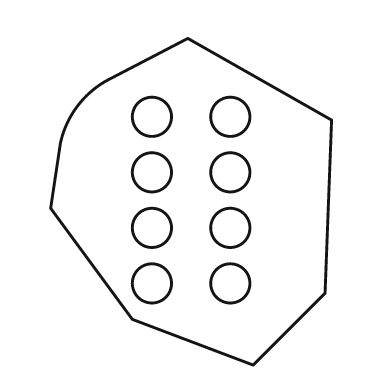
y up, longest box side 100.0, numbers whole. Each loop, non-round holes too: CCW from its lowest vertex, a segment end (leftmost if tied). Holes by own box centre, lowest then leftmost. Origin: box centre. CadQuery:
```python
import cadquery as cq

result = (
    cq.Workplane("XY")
    .moveTo(19.0, -50.0)
    .lineTo(41.0, -28.0)
    .lineTo(43.0, 25.0)
    .lineTo(-1.0, 50.0)
    .lineTo(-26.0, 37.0)
    .threePointArc((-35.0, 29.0), (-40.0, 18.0))
    .lineTo(-43.0, -2.0)
    .lineTo(-18.0, -36.0)
    .close()
    .moveTo(-12.0, -25.0)
    .circle(6.0)
    .moveTo(12.0, -25.0)
    .circle(6.0)
    .moveTo(-12.0, -8.0)
    .circle(6.0)
    .moveTo(12.0, -8.0)
    .circle(6.0)
    .moveTo(-12.0, 9.0)
    .circle(6.0)
    .moveTo(12.0, 9.0)
    .circle(6.0)
    .moveTo(-12.0, 26.0)
    .circle(6.0)
    .moveTo(12.0, 26.0)
    .circle(6.0)
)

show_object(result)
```